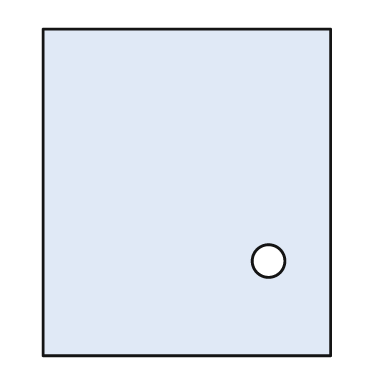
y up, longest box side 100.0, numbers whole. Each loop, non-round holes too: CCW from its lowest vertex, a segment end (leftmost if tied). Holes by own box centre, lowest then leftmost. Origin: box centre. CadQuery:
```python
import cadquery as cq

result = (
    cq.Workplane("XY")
    .moveTo(-44.0, -50.0)
    .lineTo(44.0, -50.0)
    .lineTo(44.0, 50.0)
    .lineTo(-44.0, 50.0)
    .close()
    .moveTo(25.0, -21.0)
    .circle(5.0)
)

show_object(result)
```